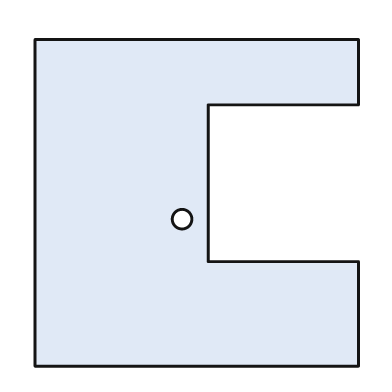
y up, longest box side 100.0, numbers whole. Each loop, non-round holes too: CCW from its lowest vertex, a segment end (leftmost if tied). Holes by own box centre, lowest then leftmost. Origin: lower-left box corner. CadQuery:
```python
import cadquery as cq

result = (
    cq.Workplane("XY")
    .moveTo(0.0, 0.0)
    .lineTo(99.0, 0.0)
    .lineTo(99.0, 32.0)
    .lineTo(53.0, 32.0)
    .lineTo(53.0, 80.0)
    .lineTo(99.0, 80.0)
    .lineTo(99.0, 100.0)
    .lineTo(0.0, 100.0)
    .close()
    .moveTo(45.0, 45.0)
    .circle(3.0)
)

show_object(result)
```